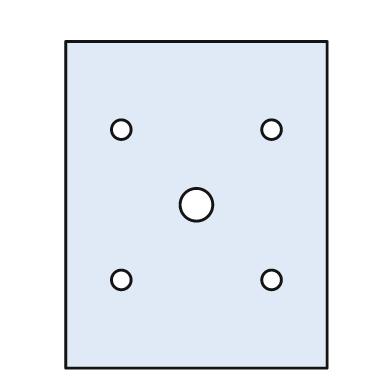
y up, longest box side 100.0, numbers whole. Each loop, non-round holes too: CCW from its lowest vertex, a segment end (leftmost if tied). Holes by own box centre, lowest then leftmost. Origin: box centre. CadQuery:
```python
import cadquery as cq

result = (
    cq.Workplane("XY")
    .moveTo(-40.0, -50.0)
    .lineTo(40.0, -50.0)
    .lineTo(40.0, 50.0)
    .lineTo(-40.0, 50.0)
    .close()
    .moveTo(-23.0, -23.0)
    .circle(3.0)
    .moveTo(23.0, -23.0)
    .circle(3.0)
    .moveTo(0.0, 0.0)
    .circle(5.0)
    .moveTo(-23.0, 23.0)
    .circle(3.0)
    .moveTo(23.0, 23.0)
    .circle(3.0)
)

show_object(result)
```